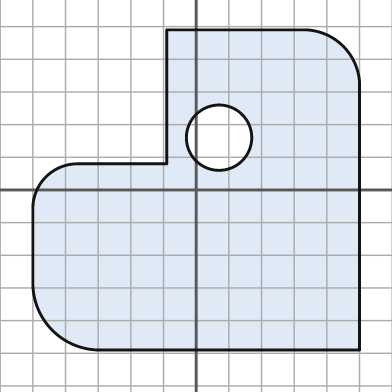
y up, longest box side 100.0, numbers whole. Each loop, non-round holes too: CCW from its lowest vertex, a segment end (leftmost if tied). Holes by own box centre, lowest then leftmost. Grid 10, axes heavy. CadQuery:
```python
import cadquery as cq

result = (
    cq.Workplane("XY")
    .moveTo(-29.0, -49.0)
    .lineTo(50.0, -49.0)
    .lineTo(50.0, 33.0)
    .threePointArc((45.0, 44.0), (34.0, 49.0))
    .lineTo(-9.0, 49.0)
    .lineTo(-9.0, 8.0)
    .lineTo(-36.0, 8.0)
    .threePointArc((-46.0, 4.0), (-50.0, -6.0))
    .lineTo(-50.0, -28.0)
    .threePointArc((-44.0, -43.0), (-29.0, -49.0))
    .close()
    .moveTo(7.0, 16.0)
    .circle(10.0)
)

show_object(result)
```